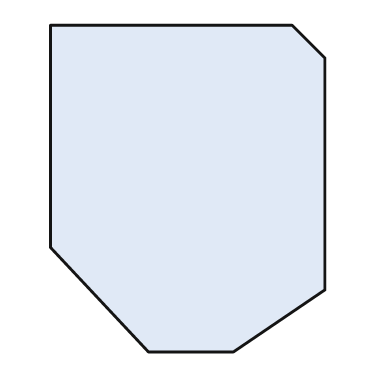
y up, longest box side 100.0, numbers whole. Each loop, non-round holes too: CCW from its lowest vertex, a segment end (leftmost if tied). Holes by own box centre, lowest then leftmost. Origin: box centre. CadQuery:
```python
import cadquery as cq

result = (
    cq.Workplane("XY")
    .moveTo(-12.0, -50.0)
    .lineTo(14.0, -50.0)
    .lineTo(42.0, -31.0)
    .lineTo(42.0, 40.0)
    .lineTo(32.0, 50.0)
    .lineTo(-42.0, 50.0)
    .lineTo(-42.0, -18.0)
    .close()
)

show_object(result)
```